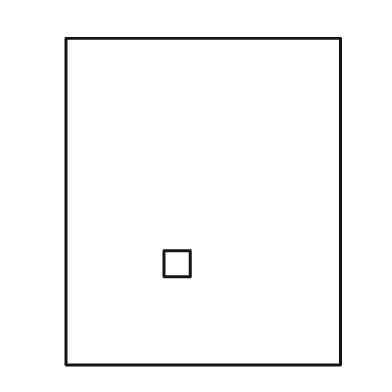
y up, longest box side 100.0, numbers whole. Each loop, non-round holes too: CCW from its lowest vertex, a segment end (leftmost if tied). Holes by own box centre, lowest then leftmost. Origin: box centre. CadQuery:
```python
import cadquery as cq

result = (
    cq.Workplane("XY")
    .moveTo(-42.0, -50.0)
    .lineTo(42.0, -50.0)
    .lineTo(42.0, 50.0)
    .lineTo(-42.0, 50.0)
    .close()
    .moveTo(-12.0, -23.0)
    .lineTo(-4.0, -23.0)
    .lineTo(-4.0, -15.0)
    .lineTo(-12.0, -15.0)
    .close()
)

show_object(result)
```